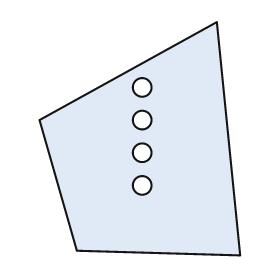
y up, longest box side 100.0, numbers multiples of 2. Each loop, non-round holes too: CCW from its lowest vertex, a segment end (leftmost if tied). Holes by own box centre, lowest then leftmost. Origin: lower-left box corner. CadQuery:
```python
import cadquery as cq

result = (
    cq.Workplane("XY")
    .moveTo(86.0, 0.0)
    .lineTo(76.0, 100.0)
    .lineTo(0.0, 58.0)
    .lineTo(16.0, 2.0)
    .close()
    .moveTo(44.0, 30.0)
    .circle(4.0)
    .moveTo(44.0, 44.0)
    .circle(4.0)
    .moveTo(44.0, 58.0)
    .circle(4.0)
    .moveTo(44.0, 72.0)
    .circle(4.0)
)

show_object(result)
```